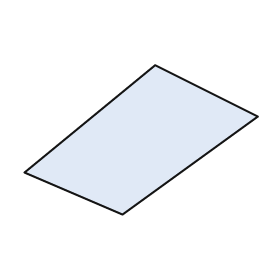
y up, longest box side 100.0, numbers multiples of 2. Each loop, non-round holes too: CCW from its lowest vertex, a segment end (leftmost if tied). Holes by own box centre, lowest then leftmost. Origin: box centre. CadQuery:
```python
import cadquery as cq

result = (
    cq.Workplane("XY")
    .moveTo(-8.0, -32.0)
    .lineTo(50.0, 10.0)
    .lineTo(6.0, 32.0)
    .lineTo(-50.0, -14.0)
    .close()
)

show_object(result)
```